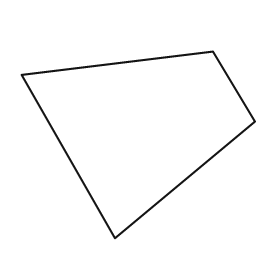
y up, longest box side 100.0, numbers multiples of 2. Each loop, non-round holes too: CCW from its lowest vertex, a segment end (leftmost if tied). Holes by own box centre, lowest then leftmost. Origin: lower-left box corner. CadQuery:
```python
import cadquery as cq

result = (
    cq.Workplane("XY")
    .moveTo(40.0, 0.0)
    .lineTo(100.0, 50.0)
    .lineTo(82.0, 80.0)
    .lineTo(0.0, 70.0)
    .close()
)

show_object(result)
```